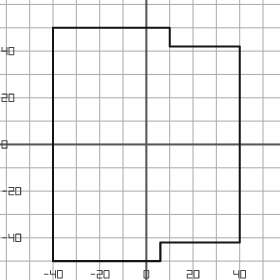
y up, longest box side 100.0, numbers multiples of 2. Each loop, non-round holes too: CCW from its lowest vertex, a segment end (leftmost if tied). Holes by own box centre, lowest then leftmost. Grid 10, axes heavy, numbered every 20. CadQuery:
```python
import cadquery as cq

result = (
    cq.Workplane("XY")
    .moveTo(-40.0, -50.0)
    .lineTo(6.0, -50.0)
    .lineTo(6.0, -42.0)
    .lineTo(40.0, -42.0)
    .lineTo(40.0, 42.0)
    .lineTo(10.0, 42.0)
    .lineTo(10.0, 50.0)
    .lineTo(-40.0, 50.0)
    .close()
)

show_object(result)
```